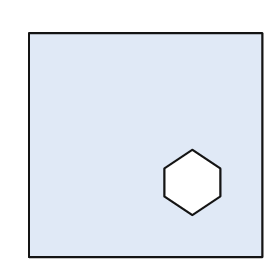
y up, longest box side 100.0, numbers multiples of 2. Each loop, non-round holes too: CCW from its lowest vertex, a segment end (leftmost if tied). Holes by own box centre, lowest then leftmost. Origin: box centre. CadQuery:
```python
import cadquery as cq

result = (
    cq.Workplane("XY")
    .moveTo(-50.0, -48.0)
    .lineTo(50.0, -48.0)
    .lineTo(50.0, 48.0)
    .lineTo(-50.0, 48.0)
    .close()
    .moveTo(20.0, -30.0)
    .lineTo(32.0, -22.0)
    .lineTo(32.0, -10.0)
    .lineTo(20.0, -2.0)
    .lineTo(8.0, -10.0)
    .lineTo(8.0, -22.0)
    .close()
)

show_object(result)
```